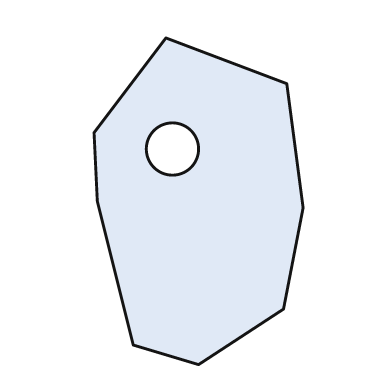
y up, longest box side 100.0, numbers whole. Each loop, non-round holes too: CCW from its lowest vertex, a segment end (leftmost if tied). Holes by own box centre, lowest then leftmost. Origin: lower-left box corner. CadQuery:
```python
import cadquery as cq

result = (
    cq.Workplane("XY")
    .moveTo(32.0, 0.0)
    .lineTo(58.0, 17.0)
    .lineTo(64.0, 48.0)
    .lineTo(59.0, 86.0)
    .lineTo(22.0, 100.0)
    .lineTo(0.0, 71.0)
    .lineTo(1.0, 50.0)
    .lineTo(12.0, 6.0)
    .close()
    .moveTo(24.0, 66.0)
    .circle(8.0)
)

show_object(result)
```